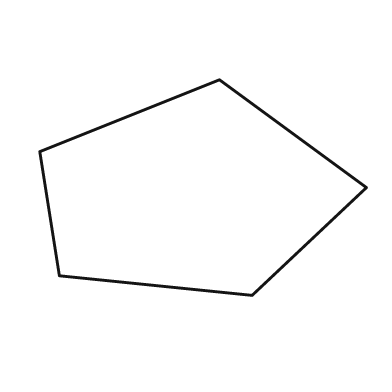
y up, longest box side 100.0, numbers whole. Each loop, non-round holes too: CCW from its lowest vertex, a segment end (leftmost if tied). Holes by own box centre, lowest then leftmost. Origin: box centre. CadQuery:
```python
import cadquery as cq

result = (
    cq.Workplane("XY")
    .moveTo(15.0, -33.0)
    .lineTo(50.0, 0.0)
    .lineTo(5.0, 33.0)
    .lineTo(-50.0, 11.0)
    .lineTo(-44.0, -27.0)
    .close()
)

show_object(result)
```